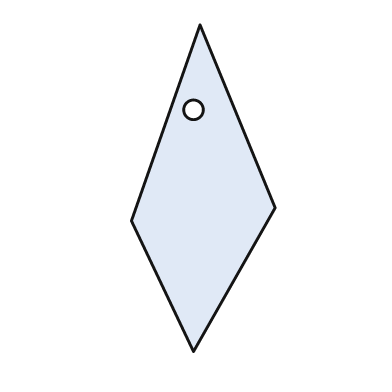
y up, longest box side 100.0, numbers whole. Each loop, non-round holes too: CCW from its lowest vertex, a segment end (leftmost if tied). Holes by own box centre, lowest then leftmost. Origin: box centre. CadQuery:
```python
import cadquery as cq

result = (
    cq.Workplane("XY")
    .moveTo(-3.0, -50.0)
    .lineTo(22.0, -6.0)
    .lineTo(-1.0, 50.0)
    .lineTo(-22.0, -10.0)
    .close()
    .moveTo(-3.0, 24.0)
    .circle(3.0)
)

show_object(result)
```